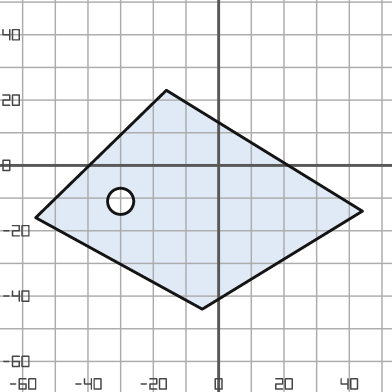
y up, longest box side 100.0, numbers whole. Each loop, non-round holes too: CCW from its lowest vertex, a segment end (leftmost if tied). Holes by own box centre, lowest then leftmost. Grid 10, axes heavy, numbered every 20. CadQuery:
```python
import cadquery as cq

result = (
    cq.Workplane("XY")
    .moveTo(-5.0, -44.0)
    .lineTo(44.0, -14.0)
    .lineTo(-16.0, 23.0)
    .lineTo(-56.0, -16.0)
    .close()
    .moveTo(-30.0, -11.0)
    .circle(4.0)
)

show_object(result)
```